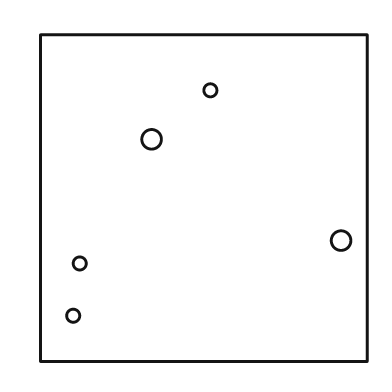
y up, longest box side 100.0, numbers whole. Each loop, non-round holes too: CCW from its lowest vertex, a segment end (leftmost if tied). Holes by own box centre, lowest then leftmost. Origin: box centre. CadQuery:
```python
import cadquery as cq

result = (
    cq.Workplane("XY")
    .moveTo(-50.0, -50.0)
    .lineTo(50.0, -50.0)
    .lineTo(50.0, 50.0)
    .lineTo(-50.0, 50.0)
    .close()
    .moveTo(-40.0, -36.0)
    .circle(2.0)
    .moveTo(-38.0, -20.0)
    .circle(2.0)
    .moveTo(42.0, -13.0)
    .circle(3.0)
    .moveTo(-16.0, 18.0)
    .circle(3.0)
    .moveTo(2.0, 33.0)
    .circle(2.0)
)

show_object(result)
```